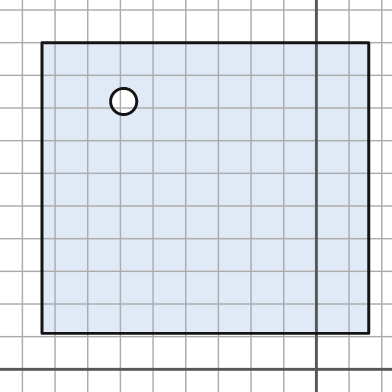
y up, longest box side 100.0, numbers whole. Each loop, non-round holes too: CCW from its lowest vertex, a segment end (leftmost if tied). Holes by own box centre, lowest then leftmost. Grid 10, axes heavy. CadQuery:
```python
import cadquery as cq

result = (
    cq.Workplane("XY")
    .moveTo(-84.0, 11.0)
    .lineTo(16.0, 11.0)
    .lineTo(16.0, 100.0)
    .lineTo(-84.0, 100.0)
    .close()
    .moveTo(-59.0, 82.0)
    .circle(4.0)
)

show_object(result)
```